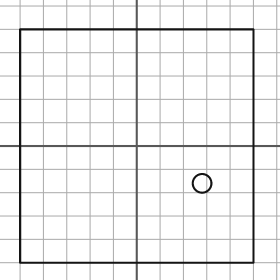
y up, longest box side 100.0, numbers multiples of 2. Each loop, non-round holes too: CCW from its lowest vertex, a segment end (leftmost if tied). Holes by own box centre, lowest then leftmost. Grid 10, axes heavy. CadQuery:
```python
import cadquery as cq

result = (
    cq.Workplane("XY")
    .moveTo(-50.0, -50.0)
    .lineTo(50.0, -50.0)
    .lineTo(50.0, 50.0)
    .lineTo(-50.0, 50.0)
    .close()
    .moveTo(28.0, -16.0)
    .circle(4.0)
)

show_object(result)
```